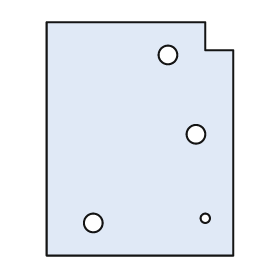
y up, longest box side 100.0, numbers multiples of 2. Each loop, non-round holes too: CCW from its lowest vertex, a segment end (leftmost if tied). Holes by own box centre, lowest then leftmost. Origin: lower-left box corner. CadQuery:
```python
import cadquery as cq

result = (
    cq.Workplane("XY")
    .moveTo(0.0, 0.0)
    .lineTo(80.0, 0.0)
    .lineTo(80.0, 88.0)
    .lineTo(68.0, 88.0)
    .lineTo(68.0, 100.0)
    .lineTo(0.0, 100.0)
    .close()
    .moveTo(20.0, 14.0)
    .circle(4.0)
    .moveTo(68.0, 16.0)
    .circle(2.0)
    .moveTo(64.0, 52.0)
    .circle(4.0)
    .moveTo(52.0, 86.0)
    .circle(4.0)
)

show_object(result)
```